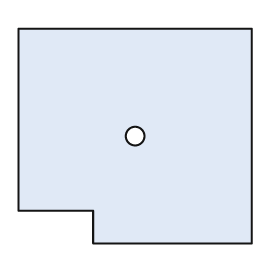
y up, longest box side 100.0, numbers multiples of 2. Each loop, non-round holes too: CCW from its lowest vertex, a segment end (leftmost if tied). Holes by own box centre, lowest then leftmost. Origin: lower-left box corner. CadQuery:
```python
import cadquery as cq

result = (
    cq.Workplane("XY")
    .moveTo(32.0, 0.0)
    .lineTo(100.0, 0.0)
    .lineTo(100.0, 92.0)
    .lineTo(0.0, 92.0)
    .lineTo(0.0, 14.0)
    .lineTo(32.0, 14.0)
    .close()
    .moveTo(50.0, 46.0)
    .circle(4.0)
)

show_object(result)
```